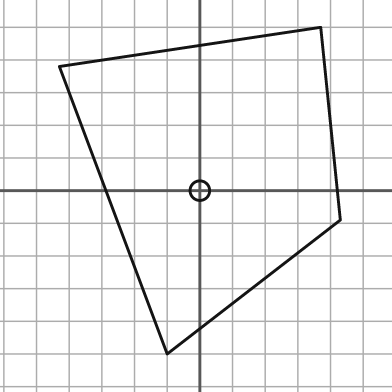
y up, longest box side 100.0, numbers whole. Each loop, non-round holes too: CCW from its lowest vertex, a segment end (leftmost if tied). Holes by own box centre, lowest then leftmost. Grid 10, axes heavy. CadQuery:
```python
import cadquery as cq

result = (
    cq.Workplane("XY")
    .moveTo(-10.0, -50.0)
    .lineTo(43.0, -9.0)
    .lineTo(37.0, 50.0)
    .lineTo(-43.0, 38.0)
    .close()
    .moveTo(0.0, 0.0)
    .circle(3.0)
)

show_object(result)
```